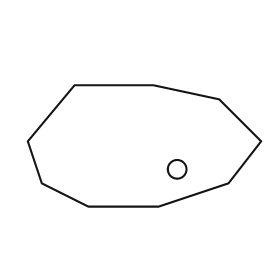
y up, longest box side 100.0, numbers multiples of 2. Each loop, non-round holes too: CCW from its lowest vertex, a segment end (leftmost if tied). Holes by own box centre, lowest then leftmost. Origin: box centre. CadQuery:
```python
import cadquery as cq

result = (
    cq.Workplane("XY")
    .moveTo(-24.0, -26.0)
    .lineTo(6.0, -26.0)
    .lineTo(36.0, -16.0)
    .lineTo(50.0, 2.0)
    .lineTo(32.0, 20.0)
    .lineTo(4.0, 26.0)
    .lineTo(-30.0, 26.0)
    .lineTo(-50.0, 2.0)
    .lineTo(-44.0, -16.0)
    .close()
    .moveTo(14.0, -10.0)
    .circle(4.0)
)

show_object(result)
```